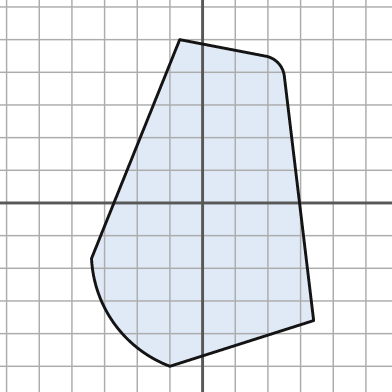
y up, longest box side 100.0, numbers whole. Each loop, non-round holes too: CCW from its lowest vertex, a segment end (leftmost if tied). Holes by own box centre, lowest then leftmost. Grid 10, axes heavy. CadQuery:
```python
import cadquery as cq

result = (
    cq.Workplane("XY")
    .moveTo(-10.0, -50.0)
    .lineTo(34.0, -36.0)
    .lineTo(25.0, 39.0)
    .threePointArc((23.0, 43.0), (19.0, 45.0))
    .lineTo(-7.0, 50.0)
    .lineTo(-34.0, -17.0)
    .threePointArc((-27.0, -37.0), (-10.0, -50.0))
    .close()
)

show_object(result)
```